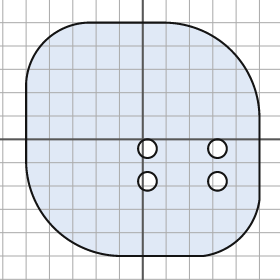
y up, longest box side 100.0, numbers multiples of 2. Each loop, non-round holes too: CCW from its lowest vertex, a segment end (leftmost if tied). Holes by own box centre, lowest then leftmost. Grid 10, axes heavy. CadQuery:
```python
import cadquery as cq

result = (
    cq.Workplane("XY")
    .moveTo(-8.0, -50.0)
    .lineTo(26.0, -50.0)
    .threePointArc((42.0, -42.0), (50.0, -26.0))
    .lineTo(50.0, 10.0)
    .threePointArc((38.0, 38.0), (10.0, 50.0))
    .lineTo(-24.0, 50.0)
    .threePointArc((-42.0, 42.0), (-50.0, 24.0))
    .lineTo(-50.0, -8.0)
    .threePointArc((-38.0, -38.0), (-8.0, -50.0))
    .close()
    .moveTo(2.0, -18.0)
    .circle(4.0)
    .moveTo(32.0, -18.0)
    .circle(4.0)
    .moveTo(2.0, -4.0)
    .circle(4.0)
    .moveTo(32.0, -4.0)
    .circle(4.0)
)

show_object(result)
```